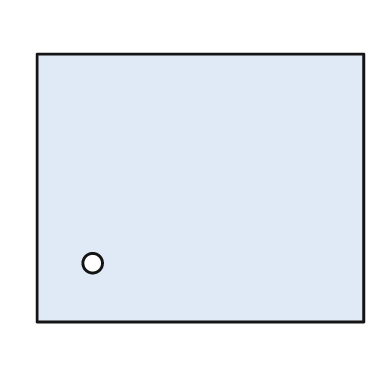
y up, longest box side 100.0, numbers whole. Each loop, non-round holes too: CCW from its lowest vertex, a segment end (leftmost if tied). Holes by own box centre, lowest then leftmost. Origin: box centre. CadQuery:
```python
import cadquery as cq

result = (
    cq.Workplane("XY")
    .moveTo(-50.0, -41.0)
    .lineTo(50.0, -41.0)
    .lineTo(50.0, 41.0)
    .lineTo(-50.0, 41.0)
    .close()
    .moveTo(-33.0, -23.0)
    .circle(3.0)
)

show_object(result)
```